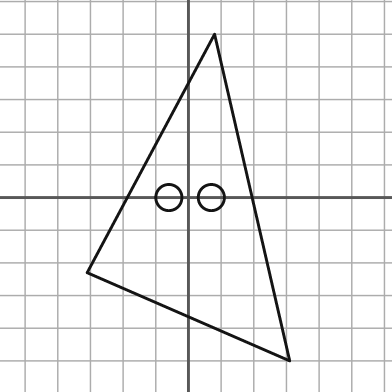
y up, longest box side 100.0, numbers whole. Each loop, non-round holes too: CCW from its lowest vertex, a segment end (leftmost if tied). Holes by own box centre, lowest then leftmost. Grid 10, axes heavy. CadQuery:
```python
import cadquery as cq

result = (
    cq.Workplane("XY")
    .moveTo(31.0, -50.0)
    .lineTo(8.0, 50.0)
    .lineTo(-31.0, -23.0)
    .close()
    .moveTo(-6.0, 0.0)
    .circle(4.0)
    .moveTo(7.0, 0.0)
    .circle(4.0)
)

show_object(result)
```